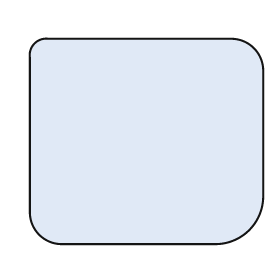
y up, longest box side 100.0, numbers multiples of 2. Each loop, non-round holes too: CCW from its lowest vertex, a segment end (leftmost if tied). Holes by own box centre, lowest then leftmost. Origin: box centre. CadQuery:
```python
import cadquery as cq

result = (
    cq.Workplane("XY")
    .moveTo(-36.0, -44.0)
    .lineTo(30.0, -44.0)
    .threePointArc((44.0, -38.0), (50.0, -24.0))
    .lineTo(50.0, 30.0)
    .threePointArc((46.0, 40.0), (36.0, 44.0))
    .lineTo(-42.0, 44.0)
    .threePointArc((-48.0, 42.0), (-50.0, 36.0))
    .lineTo(-50.0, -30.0)
    .threePointArc((-46.0, -40.0), (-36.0, -44.0))
    .close()
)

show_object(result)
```